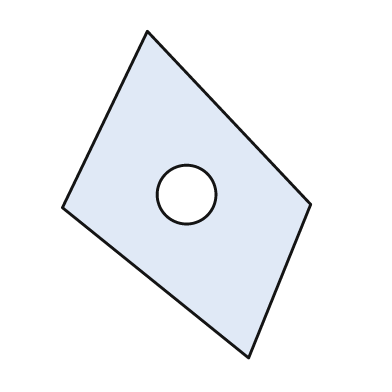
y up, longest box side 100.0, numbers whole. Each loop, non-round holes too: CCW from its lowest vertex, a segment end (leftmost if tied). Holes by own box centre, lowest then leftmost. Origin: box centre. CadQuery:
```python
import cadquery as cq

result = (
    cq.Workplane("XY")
    .moveTo(19.0, -50.0)
    .lineTo(38.0, -3.0)
    .lineTo(-12.0, 50.0)
    .lineTo(-38.0, -4.0)
    .close()
    .moveTo(0.0, 0.0)
    .circle(9.0)
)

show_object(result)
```